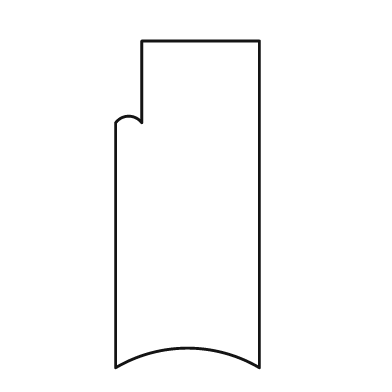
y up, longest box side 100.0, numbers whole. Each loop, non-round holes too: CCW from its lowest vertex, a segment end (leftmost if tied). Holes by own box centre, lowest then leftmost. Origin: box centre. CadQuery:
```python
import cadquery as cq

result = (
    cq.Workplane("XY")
    .moveTo(-22.0, -50.0)
    .threePointArc((0.0, -44.0), (22.0, -50.0))
    .lineTo(22.0, 50.0)
    .lineTo(-14.0, 50.0)
    .lineTo(-14.0, 25.0)
    .threePointArc((-18.0, 27.0), (-22.0, 25.0))
    .close()
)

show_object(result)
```